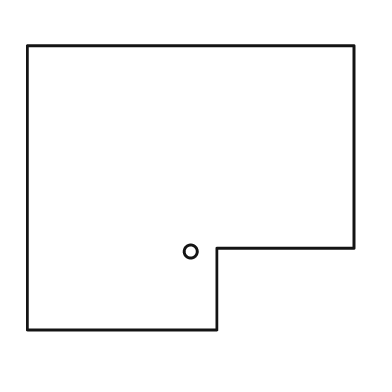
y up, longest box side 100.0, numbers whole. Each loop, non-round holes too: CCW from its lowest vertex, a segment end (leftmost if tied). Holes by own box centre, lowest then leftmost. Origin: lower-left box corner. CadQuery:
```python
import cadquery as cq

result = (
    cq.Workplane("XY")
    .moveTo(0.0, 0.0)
    .lineTo(58.0, 0.0)
    .lineTo(58.0, 25.0)
    .lineTo(100.0, 25.0)
    .lineTo(100.0, 87.0)
    .lineTo(0.0, 87.0)
    .close()
    .moveTo(50.0, 24.0)
    .circle(2.0)
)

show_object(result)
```